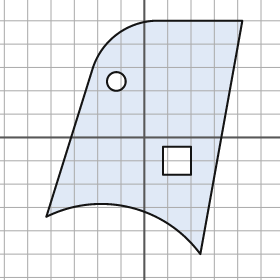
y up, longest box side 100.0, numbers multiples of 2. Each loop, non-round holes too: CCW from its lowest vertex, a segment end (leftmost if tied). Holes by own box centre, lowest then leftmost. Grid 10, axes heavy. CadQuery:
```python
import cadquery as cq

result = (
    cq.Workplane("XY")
    .moveTo(24.0, -50.0)
    .lineTo(42.0, 50.0)
    .lineTo(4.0, 50.0)
    .threePointArc((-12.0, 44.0), (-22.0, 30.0))
    .lineTo(-42.0, -34.0)
    .threePointArc((-6.0, -30.0), (24.0, -50.0))
    .close()
    .moveTo(8.0, -16.0)
    .lineTo(20.0, -16.0)
    .lineTo(20.0, -4.0)
    .lineTo(8.0, -4.0)
    .close()
    .moveTo(-12.0, 24.0)
    .circle(4.0)
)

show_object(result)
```